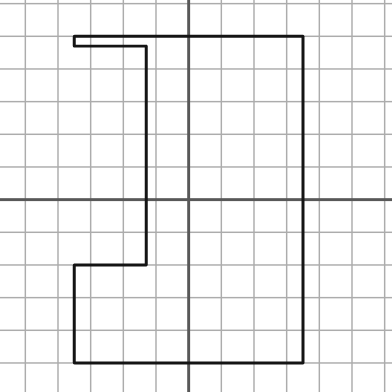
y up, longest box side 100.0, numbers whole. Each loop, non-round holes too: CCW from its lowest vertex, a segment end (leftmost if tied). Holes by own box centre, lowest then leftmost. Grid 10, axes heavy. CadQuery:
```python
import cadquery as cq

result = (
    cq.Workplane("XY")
    .moveTo(-35.0, -50.0)
    .lineTo(35.0, -50.0)
    .lineTo(35.0, 50.0)
    .lineTo(-35.0, 50.0)
    .lineTo(-35.0, 47.0)
    .lineTo(-13.0, 47.0)
    .lineTo(-13.0, -20.0)
    .lineTo(-35.0, -20.0)
    .close()
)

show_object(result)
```